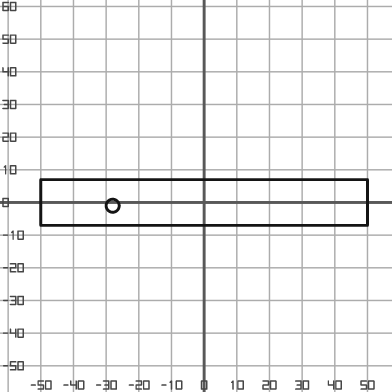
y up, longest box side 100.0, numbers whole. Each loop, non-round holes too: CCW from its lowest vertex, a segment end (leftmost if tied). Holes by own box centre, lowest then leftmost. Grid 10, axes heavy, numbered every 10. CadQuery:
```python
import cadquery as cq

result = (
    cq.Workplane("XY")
    .moveTo(-50.0, -7.0)
    .lineTo(50.0, -7.0)
    .lineTo(50.0, 7.0)
    .lineTo(-50.0, 7.0)
    .close()
    .moveTo(-28.0, -1.0)
    .circle(2.0)
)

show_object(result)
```